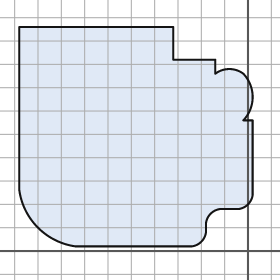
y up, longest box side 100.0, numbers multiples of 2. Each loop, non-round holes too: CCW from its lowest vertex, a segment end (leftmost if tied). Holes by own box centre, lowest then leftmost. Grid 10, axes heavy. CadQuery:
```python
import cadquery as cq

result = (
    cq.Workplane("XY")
    .moveTo(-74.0, 2.0)
    .lineTo(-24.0, 2.0)
    .threePointArc((-20.0, 4.0), (-18.0, 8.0))
    .lineTo(-18.0, 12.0)
    .threePointArc((-16.0, 16.0), (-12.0, 18.0))
    .lineTo(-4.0, 18.0)
    .threePointArc((0.0, 20.0), (2.0, 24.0))
    .lineTo(2.0, 56.0)
    .lineTo(-2.0, 56.0)
    .threePointArc((2.0, 66.0), (-2.0, 76.0))
    .threePointArc((-8.0, 78.0), (-14.0, 76.0))
    .lineTo(-14.0, 82.0)
    .lineTo(-32.0, 82.0)
    .lineTo(-32.0, 96.0)
    .lineTo(-98.0, 96.0)
    .lineTo(-98.0, 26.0)
    .threePointArc((-90.0, 10.0), (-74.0, 2.0))
    .close()
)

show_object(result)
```